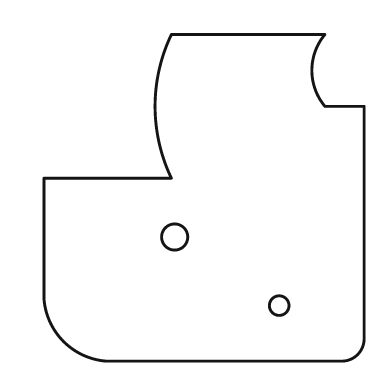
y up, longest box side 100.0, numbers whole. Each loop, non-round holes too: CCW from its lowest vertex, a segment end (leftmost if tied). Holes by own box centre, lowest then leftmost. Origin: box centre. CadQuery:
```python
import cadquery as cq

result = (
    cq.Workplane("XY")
    .moveTo(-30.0, -50.0)
    .lineTo(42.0, -50.0)
    .threePointArc((47.0, -48.0), (49.0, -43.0))
    .lineTo(49.0, 28.0)
    .lineTo(37.0, 28.0)
    .threePointArc((33.0, 39.0), (37.0, 50.0))
    .lineTo(-10.0, 50.0)
    .threePointArc((-15.0, 28.0), (-10.0, 6.0))
    .lineTo(-49.0, 6.0)
    .lineTo(-49.0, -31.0)
    .threePointArc((-43.0, -44.0), (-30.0, -50.0))
    .close()
    .moveTo(23.0, -33.0)
    .circle(3.0)
    .moveTo(-9.0, -12.0)
    .circle(4.0)
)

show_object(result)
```